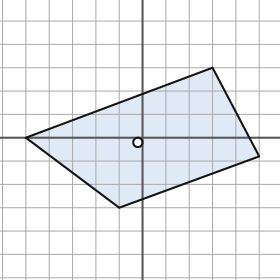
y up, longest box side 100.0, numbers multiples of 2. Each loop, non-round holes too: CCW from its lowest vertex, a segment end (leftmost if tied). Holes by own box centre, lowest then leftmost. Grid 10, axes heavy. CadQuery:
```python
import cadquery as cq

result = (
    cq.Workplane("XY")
    .moveTo(-10.0, -30.0)
    .lineTo(50.0, -8.0)
    .lineTo(30.0, 30.0)
    .lineTo(-50.0, 0.0)
    .close()
    .moveTo(-2.0, -2.0)
    .circle(2.0)
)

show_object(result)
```